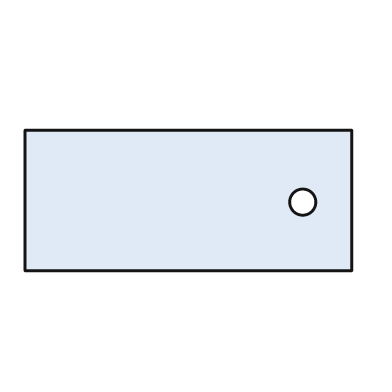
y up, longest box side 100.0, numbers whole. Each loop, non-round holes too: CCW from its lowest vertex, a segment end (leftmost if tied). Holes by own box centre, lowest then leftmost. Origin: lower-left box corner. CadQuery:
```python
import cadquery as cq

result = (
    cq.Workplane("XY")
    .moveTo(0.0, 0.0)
    .lineTo(100.0, 0.0)
    .lineTo(100.0, 43.0)
    .lineTo(0.0, 43.0)
    .close()
    .moveTo(85.0, 21.0)
    .circle(4.0)
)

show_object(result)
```